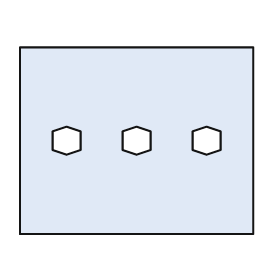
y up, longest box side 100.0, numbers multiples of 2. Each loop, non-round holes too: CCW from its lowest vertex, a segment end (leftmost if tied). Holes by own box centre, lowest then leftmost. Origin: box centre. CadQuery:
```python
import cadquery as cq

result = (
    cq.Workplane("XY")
    .moveTo(-50.0, -40.0)
    .lineTo(50.0, -40.0)
    .lineTo(50.0, 40.0)
    .lineTo(-50.0, 40.0)
    .close()
    .moveTo(-30.0, -6.0)
    .lineTo(-24.0, -4.0)
    .lineTo(-24.0, 4.0)
    .lineTo(-30.0, 6.0)
    .lineTo(-36.0, 4.0)
    .lineTo(-36.0, -4.0)
    .close()
    .moveTo(0.0, -6.0)
    .lineTo(6.0, -4.0)
    .lineTo(6.0, 4.0)
    .lineTo(0.0, 6.0)
    .lineTo(-6.0, 4.0)
    .lineTo(-6.0, -4.0)
    .close()
    .moveTo(30.0, -6.0)
    .lineTo(36.0, -4.0)
    .lineTo(36.0, 4.0)
    .lineTo(30.0, 6.0)
    .lineTo(24.0, 4.0)
    .lineTo(24.0, -4.0)
    .close()
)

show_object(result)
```